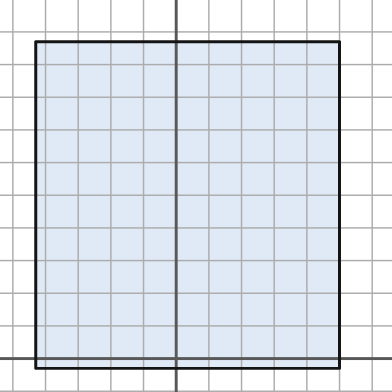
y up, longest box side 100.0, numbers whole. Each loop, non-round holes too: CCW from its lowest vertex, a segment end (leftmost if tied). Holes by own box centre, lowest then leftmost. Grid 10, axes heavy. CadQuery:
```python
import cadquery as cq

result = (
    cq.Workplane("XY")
    .moveTo(-43.0, -3.0)
    .lineTo(50.0, -3.0)
    .lineTo(50.0, 97.0)
    .lineTo(-43.0, 97.0)
    .close()
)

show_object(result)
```